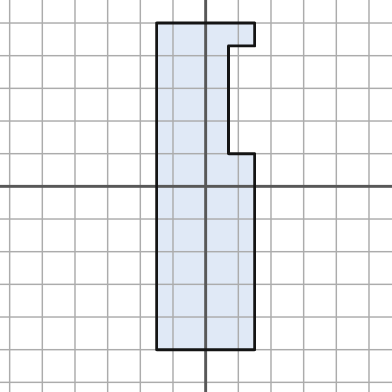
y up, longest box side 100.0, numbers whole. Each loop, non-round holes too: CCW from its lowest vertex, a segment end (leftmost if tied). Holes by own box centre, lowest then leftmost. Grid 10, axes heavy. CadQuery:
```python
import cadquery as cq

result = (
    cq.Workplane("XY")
    .moveTo(-15.0, -50.0)
    .lineTo(15.0, -50.0)
    .lineTo(15.0, 10.0)
    .lineTo(7.0, 10.0)
    .lineTo(7.0, 43.0)
    .lineTo(15.0, 43.0)
    .lineTo(15.0, 50.0)
    .lineTo(-15.0, 50.0)
    .close()
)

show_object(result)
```